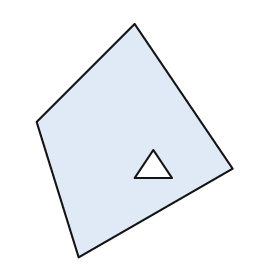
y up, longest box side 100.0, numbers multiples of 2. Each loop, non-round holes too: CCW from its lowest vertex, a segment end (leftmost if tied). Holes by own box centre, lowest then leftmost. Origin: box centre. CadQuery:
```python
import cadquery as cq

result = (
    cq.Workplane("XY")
    .moveTo(-24.0, -50.0)
    .lineTo(42.0, -12.0)
    .lineTo(0.0, 50.0)
    .lineTo(-42.0, 8.0)
    .close()
    .moveTo(0.0, -16.0)
    .lineTo(16.0, -16.0)
    .lineTo(8.0, -4.0)
    .close()
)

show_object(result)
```